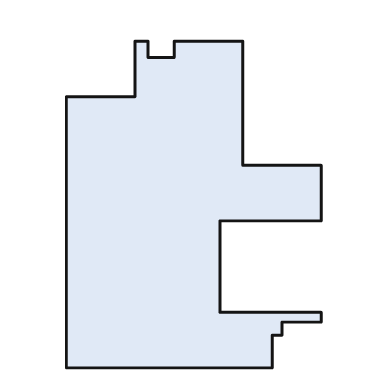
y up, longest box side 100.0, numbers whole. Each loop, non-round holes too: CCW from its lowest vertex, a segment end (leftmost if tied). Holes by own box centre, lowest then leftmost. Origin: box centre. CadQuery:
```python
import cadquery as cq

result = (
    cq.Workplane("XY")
    .moveTo(-39.0, -50.0)
    .lineTo(24.0, -50.0)
    .lineTo(24.0, -40.0)
    .lineTo(27.0, -40.0)
    .lineTo(27.0, -36.0)
    .lineTo(39.0, -36.0)
    .lineTo(39.0, -33.0)
    .lineTo(8.0, -33.0)
    .lineTo(8.0, -5.0)
    .lineTo(39.0, -5.0)
    .lineTo(39.0, 12.0)
    .lineTo(15.0, 12.0)
    .lineTo(15.0, 50.0)
    .lineTo(-6.0, 50.0)
    .lineTo(-6.0, 45.0)
    .lineTo(-14.0, 45.0)
    .lineTo(-14.0, 50.0)
    .lineTo(-18.0, 50.0)
    .lineTo(-18.0, 33.0)
    .lineTo(-39.0, 33.0)
    .close()
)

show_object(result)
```